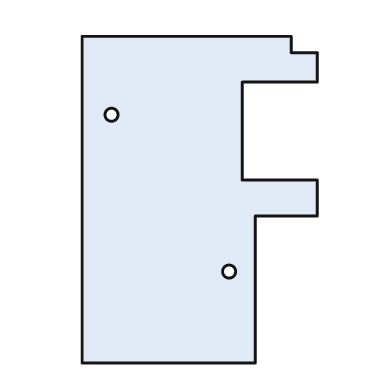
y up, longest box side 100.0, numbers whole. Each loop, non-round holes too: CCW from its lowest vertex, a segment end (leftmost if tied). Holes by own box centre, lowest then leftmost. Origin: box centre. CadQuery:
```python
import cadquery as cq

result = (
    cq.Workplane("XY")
    .moveTo(-36.0, -50.0)
    .lineTo(17.0, -50.0)
    .lineTo(17.0, -5.0)
    .lineTo(36.0, -5.0)
    .lineTo(36.0, 6.0)
    .lineTo(13.0, 6.0)
    .lineTo(13.0, 36.0)
    .lineTo(36.0, 36.0)
    .lineTo(36.0, 45.0)
    .lineTo(28.0, 45.0)
    .lineTo(28.0, 50.0)
    .lineTo(-36.0, 50.0)
    .close()
    .moveTo(9.0, -22.0)
    .circle(2.0)
    .moveTo(-27.0, 26.0)
    .circle(2.0)
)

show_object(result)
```